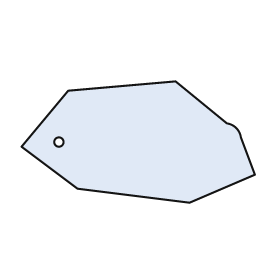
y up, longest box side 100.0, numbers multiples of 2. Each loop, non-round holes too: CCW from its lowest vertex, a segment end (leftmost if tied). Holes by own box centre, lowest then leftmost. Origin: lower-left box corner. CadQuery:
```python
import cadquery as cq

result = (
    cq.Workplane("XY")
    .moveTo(72.0, 0.0)
    .lineTo(100.0, 12.0)
    .lineTo(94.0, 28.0)
    .threePointArc((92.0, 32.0), (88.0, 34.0))
    .lineTo(66.0, 52.0)
    .lineTo(20.0, 48.0)
    .lineTo(0.0, 24.0)
    .lineTo(24.0, 6.0)
    .close()
    .moveTo(16.0, 26.0)
    .circle(2.0)
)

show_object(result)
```